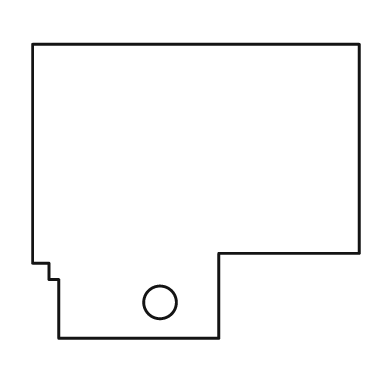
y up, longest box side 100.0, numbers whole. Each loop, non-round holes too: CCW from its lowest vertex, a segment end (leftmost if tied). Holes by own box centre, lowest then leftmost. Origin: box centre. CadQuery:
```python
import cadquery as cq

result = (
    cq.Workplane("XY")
    .moveTo(-42.0, -45.0)
    .lineTo(7.0, -45.0)
    .lineTo(7.0, -19.0)
    .lineTo(50.0, -19.0)
    .lineTo(50.0, 45.0)
    .lineTo(-50.0, 45.0)
    .lineTo(-50.0, -22.0)
    .lineTo(-45.0, -22.0)
    .lineTo(-45.0, -27.0)
    .lineTo(-42.0, -27.0)
    .close()
    .moveTo(-11.0, -34.0)
    .circle(5.0)
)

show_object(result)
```